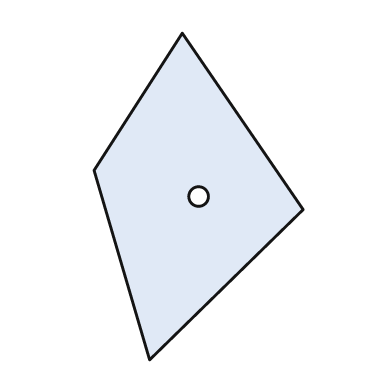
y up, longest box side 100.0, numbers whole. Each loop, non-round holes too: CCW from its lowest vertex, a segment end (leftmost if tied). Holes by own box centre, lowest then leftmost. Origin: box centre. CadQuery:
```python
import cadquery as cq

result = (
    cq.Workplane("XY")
    .moveTo(-15.0, -50.0)
    .lineTo(32.0, -4.0)
    .lineTo(-5.0, 50.0)
    .lineTo(-32.0, 8.0)
    .close()
    .moveTo(0.0, 0.0)
    .circle(3.0)
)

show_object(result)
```